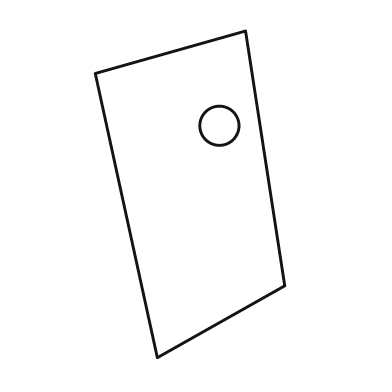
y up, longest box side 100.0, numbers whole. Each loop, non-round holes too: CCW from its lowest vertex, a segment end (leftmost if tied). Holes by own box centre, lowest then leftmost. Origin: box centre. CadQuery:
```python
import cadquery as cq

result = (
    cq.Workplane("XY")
    .moveTo(-10.0, -50.0)
    .lineTo(29.0, -28.0)
    .lineTo(17.0, 50.0)
    .lineTo(-29.0, 37.0)
    .close()
    .moveTo(9.0, 21.0)
    .circle(6.0)
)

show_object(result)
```